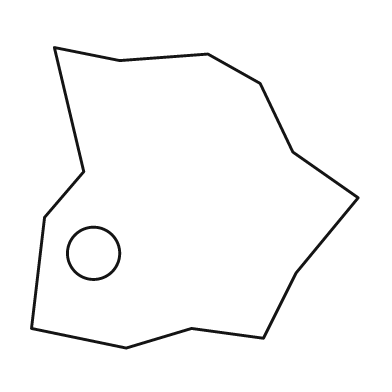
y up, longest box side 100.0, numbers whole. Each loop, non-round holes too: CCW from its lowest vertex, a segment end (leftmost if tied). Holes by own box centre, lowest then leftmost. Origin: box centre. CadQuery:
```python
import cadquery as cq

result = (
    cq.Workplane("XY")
    .moveTo(-21.0, -46.0)
    .lineTo(-1.0, -40.0)
    .lineTo(21.0, -43.0)
    .lineTo(31.0, -23.0)
    .lineTo(50.0, 0.0)
    .lineTo(30.0, 14.0)
    .lineTo(20.0, 35.0)
    .lineTo(4.0, 44.0)
    .lineTo(-23.0, 42.0)
    .lineTo(-43.0, 46.0)
    .lineTo(-34.0, 8.0)
    .lineTo(-46.0, -6.0)
    .lineTo(-50.0, -40.0)
    .close()
    .moveTo(-31.0, -17.0)
    .circle(8.0)
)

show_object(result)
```